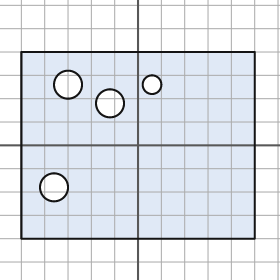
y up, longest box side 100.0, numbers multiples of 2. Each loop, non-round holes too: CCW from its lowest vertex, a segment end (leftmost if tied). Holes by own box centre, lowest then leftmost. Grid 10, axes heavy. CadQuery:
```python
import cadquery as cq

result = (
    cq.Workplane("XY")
    .moveTo(-50.0, -40.0)
    .lineTo(50.0, -40.0)
    .lineTo(50.0, 40.0)
    .lineTo(-50.0, 40.0)
    .close()
    .moveTo(-36.0, -18.0)
    .circle(6.0)
    .moveTo(-12.0, 18.0)
    .circle(6.0)
    .moveTo(-30.0, 26.0)
    .circle(6.0)
    .moveTo(6.0, 26.0)
    .circle(4.0)
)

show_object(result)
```